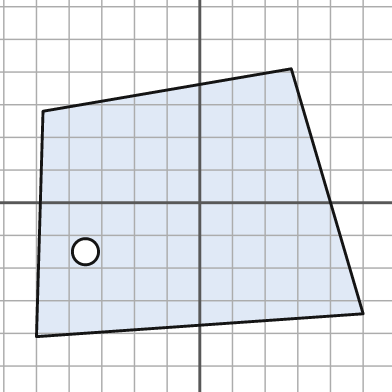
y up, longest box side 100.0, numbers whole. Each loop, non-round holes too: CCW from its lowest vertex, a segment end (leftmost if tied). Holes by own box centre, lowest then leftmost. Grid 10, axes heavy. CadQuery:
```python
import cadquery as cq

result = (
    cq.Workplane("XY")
    .moveTo(-50.0, -41.0)
    .lineTo(50.0, -34.0)
    .lineTo(28.0, 41.0)
    .lineTo(-48.0, 28.0)
    .close()
    .moveTo(-35.0, -15.0)
    .circle(4.0)
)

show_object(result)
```